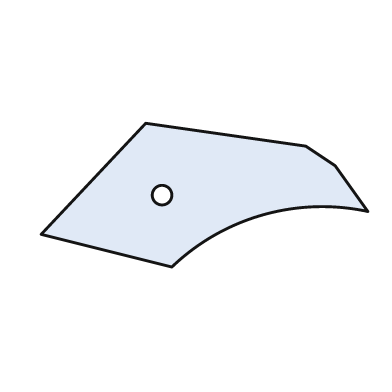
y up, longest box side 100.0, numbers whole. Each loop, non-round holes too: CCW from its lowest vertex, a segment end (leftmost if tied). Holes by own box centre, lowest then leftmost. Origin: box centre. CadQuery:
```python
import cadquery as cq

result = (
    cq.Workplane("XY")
    .moveTo(-10.0, -22.0)
    .threePointArc((18.0, -6.0), (50.0, -5.0))
    .lineTo(40.0, 9.0)
    .lineTo(31.0, 15.0)
    .lineTo(-18.0, 22.0)
    .lineTo(-50.0, -12.0)
    .close()
    .moveTo(-13.0, 0.0)
    .circle(3.0)
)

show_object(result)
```